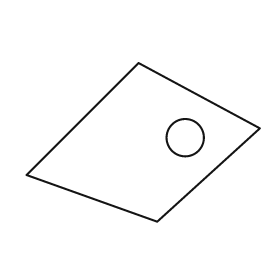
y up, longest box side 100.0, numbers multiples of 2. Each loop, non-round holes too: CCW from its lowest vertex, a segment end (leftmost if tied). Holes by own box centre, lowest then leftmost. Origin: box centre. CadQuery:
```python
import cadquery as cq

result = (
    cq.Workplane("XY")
    .moveTo(6.0, -34.0)
    .lineTo(50.0, 6.0)
    .lineTo(-2.0, 34.0)
    .lineTo(-50.0, -14.0)
    .close()
    .moveTo(18.0, 2.0)
    .circle(8.0)
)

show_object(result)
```